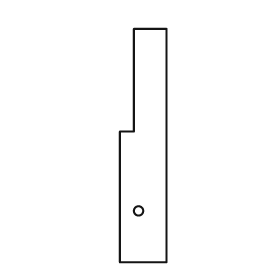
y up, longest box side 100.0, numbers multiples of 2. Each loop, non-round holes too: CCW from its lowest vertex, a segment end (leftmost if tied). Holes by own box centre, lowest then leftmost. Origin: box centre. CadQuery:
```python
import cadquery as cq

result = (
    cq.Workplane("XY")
    .moveTo(-10.0, -50.0)
    .lineTo(10.0, -50.0)
    .lineTo(10.0, 50.0)
    .lineTo(-4.0, 50.0)
    .lineTo(-4.0, 6.0)
    .lineTo(-10.0, 6.0)
    .close()
    .moveTo(-2.0, -28.0)
    .circle(2.0)
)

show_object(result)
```